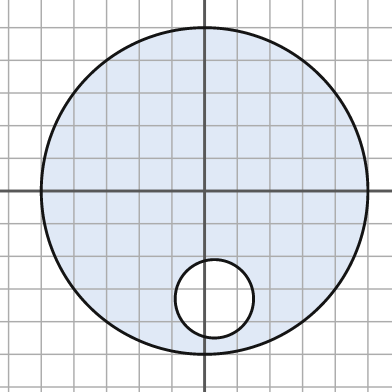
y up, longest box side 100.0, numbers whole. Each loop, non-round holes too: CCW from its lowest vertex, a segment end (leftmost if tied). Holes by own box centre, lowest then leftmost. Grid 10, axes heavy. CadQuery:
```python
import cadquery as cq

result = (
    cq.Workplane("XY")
    .moveTo(0.0, 0.0)
    .circle(50.0)
    .moveTo(3.0, -33.0)
    .circle(12.0)
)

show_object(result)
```